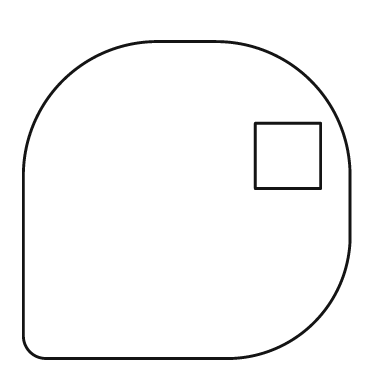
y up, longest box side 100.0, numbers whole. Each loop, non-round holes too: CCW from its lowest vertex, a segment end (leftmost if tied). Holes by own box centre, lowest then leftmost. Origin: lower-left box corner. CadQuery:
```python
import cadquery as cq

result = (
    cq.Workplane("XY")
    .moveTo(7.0, 0.0)
    .lineTo(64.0, 0.0)
    .threePointArc((89.0, 11.0), (100.0, 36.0))
    .lineTo(100.0, 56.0)
    .threePointArc((88.0, 85.0), (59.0, 97.0))
    .lineTo(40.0, 97.0)
    .threePointArc((12.0, 85.0), (0.0, 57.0))
    .lineTo(0.0, 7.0)
    .threePointArc((2.0, 2.0), (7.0, 0.0))
    .close()
    .moveTo(71.0, 52.0)
    .lineTo(91.0, 52.0)
    .lineTo(91.0, 72.0)
    .lineTo(71.0, 72.0)
    .close()
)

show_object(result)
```